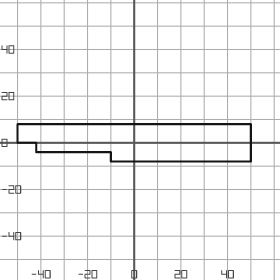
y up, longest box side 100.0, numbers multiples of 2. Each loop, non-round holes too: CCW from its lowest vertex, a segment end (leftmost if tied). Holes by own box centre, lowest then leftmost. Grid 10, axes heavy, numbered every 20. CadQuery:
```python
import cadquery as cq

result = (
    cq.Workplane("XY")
    .moveTo(-10.0, -8.0)
    .lineTo(50.0, -8.0)
    .lineTo(50.0, 8.0)
    .lineTo(-50.0, 8.0)
    .lineTo(-50.0, 0.0)
    .lineTo(-42.0, 0.0)
    .lineTo(-42.0, -4.0)
    .lineTo(-10.0, -4.0)
    .close()
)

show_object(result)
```